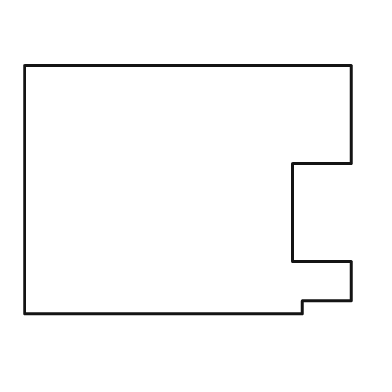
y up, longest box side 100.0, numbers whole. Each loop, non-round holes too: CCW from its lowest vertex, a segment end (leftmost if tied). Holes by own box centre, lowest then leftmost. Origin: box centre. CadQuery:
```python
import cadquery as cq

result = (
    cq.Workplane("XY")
    .moveTo(-50.0, -38.0)
    .lineTo(35.0, -38.0)
    .lineTo(35.0, -34.0)
    .lineTo(50.0, -34.0)
    .lineTo(50.0, -22.0)
    .lineTo(32.0, -22.0)
    .lineTo(32.0, 8.0)
    .lineTo(50.0, 8.0)
    .lineTo(50.0, 38.0)
    .lineTo(-50.0, 38.0)
    .close()
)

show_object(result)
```